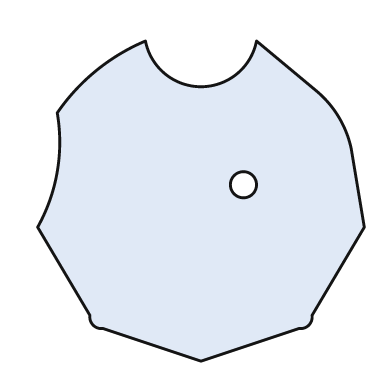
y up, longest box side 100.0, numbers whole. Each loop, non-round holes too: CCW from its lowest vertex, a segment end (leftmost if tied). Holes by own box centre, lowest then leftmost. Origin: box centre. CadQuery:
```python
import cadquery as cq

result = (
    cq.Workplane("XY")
    .moveTo(0.0, -49.0)
    .lineTo(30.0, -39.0)
    .threePointArc((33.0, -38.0), (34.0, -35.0))
    .lineTo(50.0, -8.0)
    .lineTo(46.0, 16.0)
    .threePointArc((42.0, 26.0), (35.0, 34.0))
    .lineTo(17.0, 49.0)
    .threePointArc((0.0, 35.0), (-17.0, 49.0))
    .threePointArc((-32.0, 40.0), (-44.0, 27.0))
    .threePointArc((-44.0, 9.0), (-50.0, -8.0))
    .lineTo(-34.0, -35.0)
    .threePointArc((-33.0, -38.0), (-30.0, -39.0))
    .close()
    .moveTo(13.0, 5.0)
    .circle(4.0)
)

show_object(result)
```